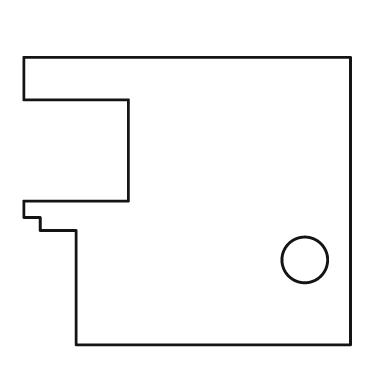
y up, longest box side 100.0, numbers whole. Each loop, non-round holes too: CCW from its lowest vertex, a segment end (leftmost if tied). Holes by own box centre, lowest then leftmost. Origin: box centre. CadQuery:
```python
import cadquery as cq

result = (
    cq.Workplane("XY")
    .moveTo(-34.0, -44.0)
    .lineTo(50.0, -44.0)
    .lineTo(50.0, 44.0)
    .lineTo(-50.0, 44.0)
    .lineTo(-50.0, 31.0)
    .lineTo(-18.0, 31.0)
    .lineTo(-18.0, 0.0)
    .lineTo(-50.0, 0.0)
    .lineTo(-50.0, -5.0)
    .lineTo(-45.0, -5.0)
    .lineTo(-45.0, -9.0)
    .lineTo(-34.0, -9.0)
    .close()
    .moveTo(36.0, -18.0)
    .circle(7.0)
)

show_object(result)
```